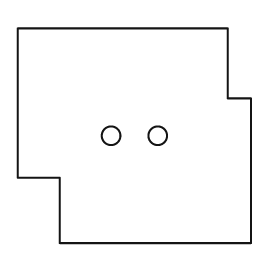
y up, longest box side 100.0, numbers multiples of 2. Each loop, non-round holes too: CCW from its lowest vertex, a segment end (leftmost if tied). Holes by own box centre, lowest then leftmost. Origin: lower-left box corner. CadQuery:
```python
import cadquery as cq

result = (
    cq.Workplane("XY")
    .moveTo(18.0, 0.0)
    .lineTo(100.0, 0.0)
    .lineTo(100.0, 62.0)
    .lineTo(90.0, 62.0)
    .lineTo(90.0, 92.0)
    .lineTo(0.0, 92.0)
    .lineTo(0.0, 28.0)
    .lineTo(18.0, 28.0)
    .close()
    .moveTo(40.0, 46.0)
    .circle(4.0)
    .moveTo(60.0, 46.0)
    .circle(4.0)
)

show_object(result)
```